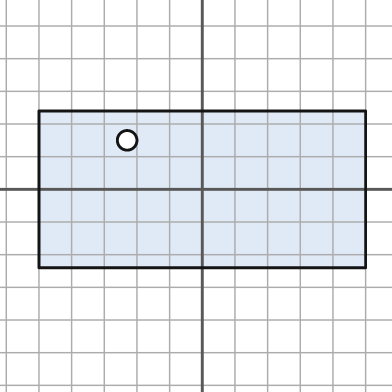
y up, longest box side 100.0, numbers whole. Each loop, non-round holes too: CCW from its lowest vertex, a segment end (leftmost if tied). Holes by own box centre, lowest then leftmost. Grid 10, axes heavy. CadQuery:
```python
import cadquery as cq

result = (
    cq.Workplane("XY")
    .moveTo(-50.0, -24.0)
    .lineTo(50.0, -24.0)
    .lineTo(50.0, 24.0)
    .lineTo(-50.0, 24.0)
    .close()
    .moveTo(-23.0, 15.0)
    .circle(3.0)
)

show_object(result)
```